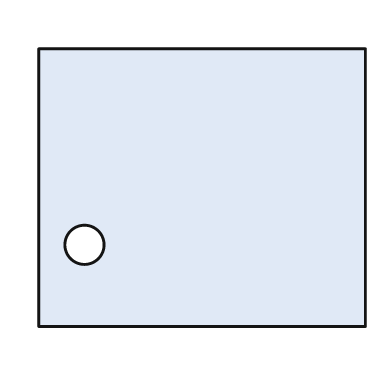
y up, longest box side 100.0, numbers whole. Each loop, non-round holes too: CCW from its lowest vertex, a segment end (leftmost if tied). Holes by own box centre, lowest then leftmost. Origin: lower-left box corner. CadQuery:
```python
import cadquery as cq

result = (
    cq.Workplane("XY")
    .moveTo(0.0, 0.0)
    .lineTo(100.0, 0.0)
    .lineTo(100.0, 85.0)
    .lineTo(0.0, 85.0)
    .close()
    .moveTo(14.0, 25.0)
    .circle(6.0)
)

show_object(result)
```